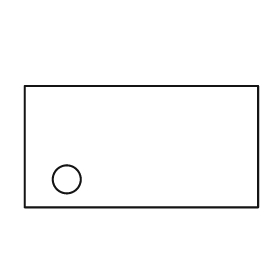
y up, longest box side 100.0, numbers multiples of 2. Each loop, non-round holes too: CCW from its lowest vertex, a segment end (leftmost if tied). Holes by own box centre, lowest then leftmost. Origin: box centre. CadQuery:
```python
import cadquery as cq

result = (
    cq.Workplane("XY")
    .moveTo(-50.0, -26.0)
    .lineTo(50.0, -26.0)
    .lineTo(50.0, 26.0)
    .lineTo(-50.0, 26.0)
    .close()
    .moveTo(-32.0, -14.0)
    .circle(6.0)
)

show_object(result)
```